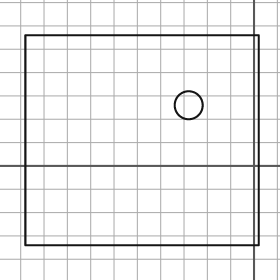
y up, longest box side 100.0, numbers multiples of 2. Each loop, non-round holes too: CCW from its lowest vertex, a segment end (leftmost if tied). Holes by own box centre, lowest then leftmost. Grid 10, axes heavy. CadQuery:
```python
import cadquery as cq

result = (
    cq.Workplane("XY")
    .moveTo(-98.0, -34.0)
    .lineTo(2.0, -34.0)
    .lineTo(2.0, 56.0)
    .lineTo(-98.0, 56.0)
    .close()
    .moveTo(-28.0, 26.0)
    .circle(6.0)
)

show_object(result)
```